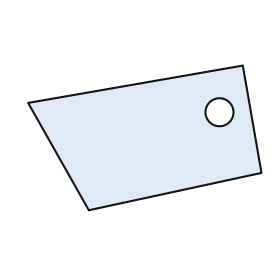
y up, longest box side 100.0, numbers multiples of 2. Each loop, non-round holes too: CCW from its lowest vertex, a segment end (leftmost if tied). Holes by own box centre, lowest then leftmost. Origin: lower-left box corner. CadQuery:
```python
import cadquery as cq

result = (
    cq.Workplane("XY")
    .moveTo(26.0, 0.0)
    .lineTo(100.0, 16.0)
    .lineTo(92.0, 62.0)
    .lineTo(0.0, 46.0)
    .close()
    .moveTo(82.0, 42.0)
    .circle(6.0)
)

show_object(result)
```